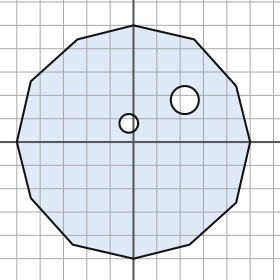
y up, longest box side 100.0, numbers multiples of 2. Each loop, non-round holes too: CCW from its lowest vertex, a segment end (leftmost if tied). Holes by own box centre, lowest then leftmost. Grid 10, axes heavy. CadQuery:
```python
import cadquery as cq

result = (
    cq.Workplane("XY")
    .moveTo(0.0, -50.0)
    .lineTo(24.0, -44.0)
    .lineTo(44.0, -26.0)
    .lineTo(50.0, 0.0)
    .lineTo(44.0, 24.0)
    .lineTo(26.0, 44.0)
    .lineTo(0.0, 50.0)
    .lineTo(-24.0, 44.0)
    .lineTo(-44.0, 26.0)
    .lineTo(-50.0, 0.0)
    .lineTo(-44.0, -24.0)
    .lineTo(-26.0, -44.0)
    .close()
    .moveTo(-2.0, 8.0)
    .circle(4.0)
    .moveTo(22.0, 18.0)
    .circle(6.0)
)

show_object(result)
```